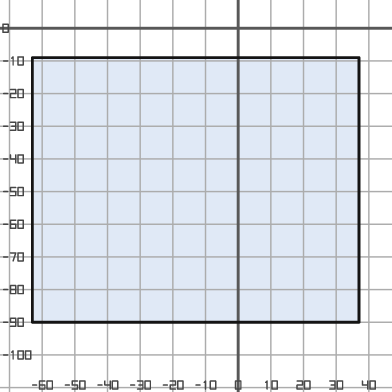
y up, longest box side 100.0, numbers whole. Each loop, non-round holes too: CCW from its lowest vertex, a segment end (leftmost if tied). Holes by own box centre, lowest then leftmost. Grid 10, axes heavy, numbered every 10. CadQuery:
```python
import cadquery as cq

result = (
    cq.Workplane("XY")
    .moveTo(-63.0, -90.0)
    .lineTo(37.0, -90.0)
    .lineTo(37.0, -9.0)
    .lineTo(-63.0, -9.0)
    .close()
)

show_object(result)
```